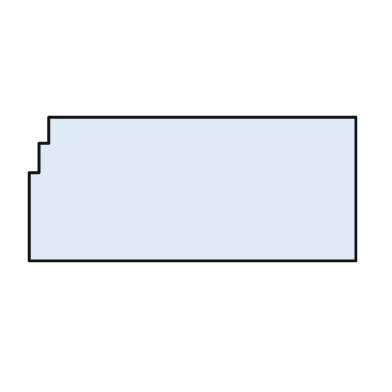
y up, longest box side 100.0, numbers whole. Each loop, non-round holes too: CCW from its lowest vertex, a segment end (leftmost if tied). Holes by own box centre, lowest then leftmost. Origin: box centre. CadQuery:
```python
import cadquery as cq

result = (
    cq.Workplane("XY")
    .moveTo(-50.0, -22.0)
    .lineTo(50.0, -22.0)
    .lineTo(50.0, 22.0)
    .lineTo(-44.0, 22.0)
    .lineTo(-44.0, 14.0)
    .lineTo(-47.0, 14.0)
    .lineTo(-47.0, 5.0)
    .lineTo(-50.0, 5.0)
    .close()
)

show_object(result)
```